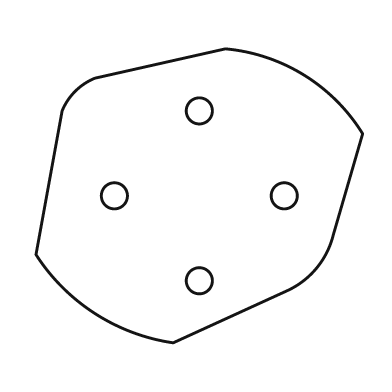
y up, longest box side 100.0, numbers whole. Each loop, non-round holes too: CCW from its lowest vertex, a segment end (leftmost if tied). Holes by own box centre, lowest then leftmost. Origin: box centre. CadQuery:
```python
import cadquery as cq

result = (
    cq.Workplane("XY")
    .moveTo(-8.0, -45.0)
    .lineTo(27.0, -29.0)
    .threePointArc((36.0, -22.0), (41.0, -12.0))
    .lineTo(50.0, 19.0)
    .threePointArc((32.0, 37.0), (8.0, 45.0))
    .lineTo(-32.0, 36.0)
    .threePointArc((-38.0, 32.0), (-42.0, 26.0))
    .lineTo(-50.0, -18.0)
    .threePointArc((-32.0, -36.0), (-8.0, -45.0))
    .close()
    .moveTo(0.0, -26.0)
    .circle(4.0)
    .moveTo(-26.0, 0.0)
    .circle(4.0)
    .moveTo(26.0, 0.0)
    .circle(4.0)
    .moveTo(0.0, 26.0)
    .circle(4.0)
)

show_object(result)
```